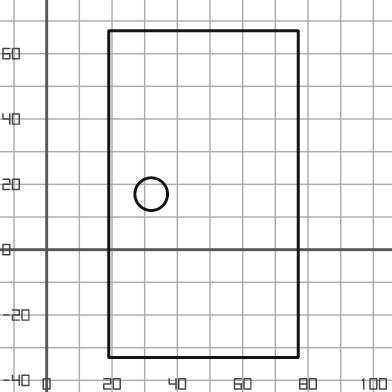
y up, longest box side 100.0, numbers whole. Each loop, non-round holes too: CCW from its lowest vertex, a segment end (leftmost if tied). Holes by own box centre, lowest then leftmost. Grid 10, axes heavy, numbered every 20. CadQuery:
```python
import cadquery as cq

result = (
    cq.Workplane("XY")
    .moveTo(19.0, -33.0)
    .lineTo(77.0, -33.0)
    .lineTo(77.0, 67.0)
    .lineTo(19.0, 67.0)
    .close()
    .moveTo(32.0, 17.0)
    .circle(5.0)
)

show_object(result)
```